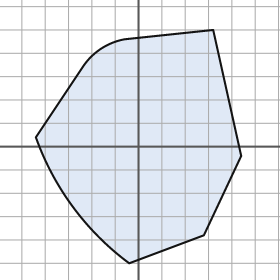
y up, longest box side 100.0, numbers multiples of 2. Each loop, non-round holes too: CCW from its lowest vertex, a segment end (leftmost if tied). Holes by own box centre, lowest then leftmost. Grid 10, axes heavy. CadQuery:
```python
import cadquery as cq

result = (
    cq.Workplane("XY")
    .moveTo(-4.0, -50.0)
    .lineTo(28.0, -38.0)
    .lineTo(44.0, -4.0)
    .lineTo(32.0, 50.0)
    .lineTo(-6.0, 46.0)
    .threePointArc((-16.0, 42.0), (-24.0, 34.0))
    .lineTo(-44.0, 4.0)
    .threePointArc((-28.0, -26.0), (-4.0, -50.0))
    .close()
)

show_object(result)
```